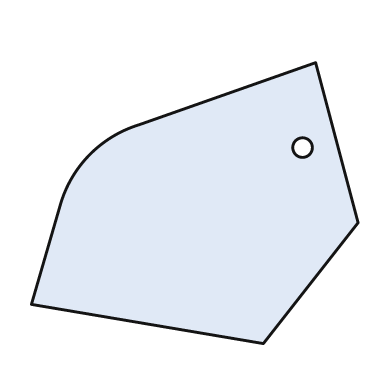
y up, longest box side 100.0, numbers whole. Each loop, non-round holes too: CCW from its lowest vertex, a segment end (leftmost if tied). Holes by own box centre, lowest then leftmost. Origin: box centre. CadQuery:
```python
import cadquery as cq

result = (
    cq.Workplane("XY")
    .moveTo(21.0, -43.0)
    .lineTo(50.0, -6.0)
    .lineTo(37.0, 43.0)
    .lineTo(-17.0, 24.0)
    .threePointArc((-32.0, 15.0), (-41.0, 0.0))
    .lineTo(-50.0, -31.0)
    .close()
    .moveTo(33.0, 17.0)
    .circle(3.0)
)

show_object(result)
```